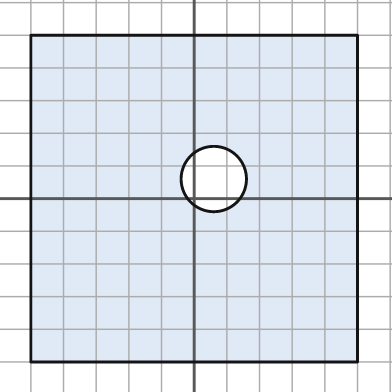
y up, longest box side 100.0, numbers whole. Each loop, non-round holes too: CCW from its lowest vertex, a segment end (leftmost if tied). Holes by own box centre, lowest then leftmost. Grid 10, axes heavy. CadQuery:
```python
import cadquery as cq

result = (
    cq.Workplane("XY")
    .moveTo(-50.0, -50.0)
    .lineTo(50.0, -50.0)
    .lineTo(50.0, 50.0)
    .lineTo(-50.0, 50.0)
    .close()
    .moveTo(6.0, 6.0)
    .circle(10.0)
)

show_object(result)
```